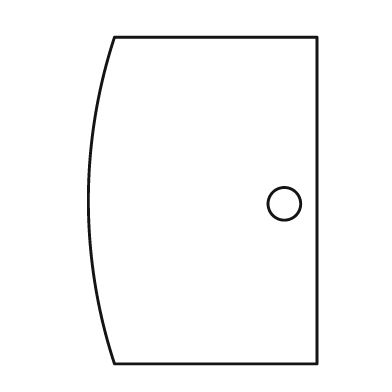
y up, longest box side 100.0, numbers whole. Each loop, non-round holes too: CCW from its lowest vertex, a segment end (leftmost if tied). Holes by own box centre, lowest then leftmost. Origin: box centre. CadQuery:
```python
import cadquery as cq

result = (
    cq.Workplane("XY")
    .moveTo(-27.0, -50.0)
    .lineTo(35.0, -50.0)
    .lineTo(35.0, 50.0)
    .lineTo(-27.0, 50.0)
    .threePointArc((-35.0, 0.0), (-27.0, -50.0))
    .close()
    .moveTo(25.0, -1.0)
    .circle(5.0)
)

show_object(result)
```